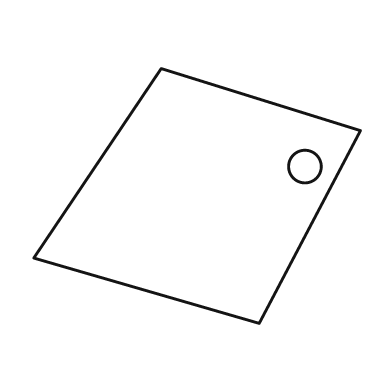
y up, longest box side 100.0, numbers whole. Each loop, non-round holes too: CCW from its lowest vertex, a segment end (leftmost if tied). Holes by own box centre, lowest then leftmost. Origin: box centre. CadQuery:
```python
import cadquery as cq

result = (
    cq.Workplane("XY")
    .moveTo(19.0, -39.0)
    .lineTo(50.0, 20.0)
    .lineTo(-11.0, 39.0)
    .lineTo(-50.0, -19.0)
    .close()
    .moveTo(33.0, 9.0)
    .circle(5.0)
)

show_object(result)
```